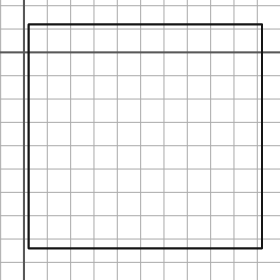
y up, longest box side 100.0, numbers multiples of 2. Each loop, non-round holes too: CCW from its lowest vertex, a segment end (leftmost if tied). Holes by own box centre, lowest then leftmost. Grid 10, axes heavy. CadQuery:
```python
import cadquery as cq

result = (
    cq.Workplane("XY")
    .moveTo(2.0, -84.0)
    .lineTo(102.0, -84.0)
    .lineTo(102.0, 12.0)
    .lineTo(2.0, 12.0)
    .close()
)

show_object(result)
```